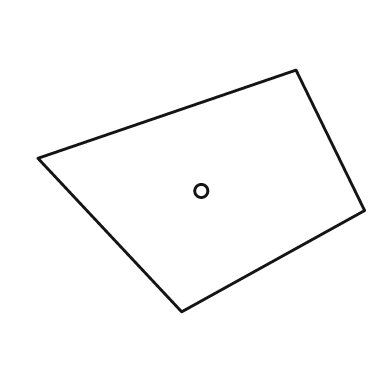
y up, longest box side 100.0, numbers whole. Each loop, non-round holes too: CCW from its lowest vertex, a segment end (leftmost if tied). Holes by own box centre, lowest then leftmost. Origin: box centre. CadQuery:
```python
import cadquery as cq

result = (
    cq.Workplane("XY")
    .moveTo(-6.0, -37.0)
    .lineTo(50.0, -6.0)
    .lineTo(29.0, 37.0)
    .lineTo(-50.0, 10.0)
    .close()
    .moveTo(0.0, 0.0)
    .circle(2.0)
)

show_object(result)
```